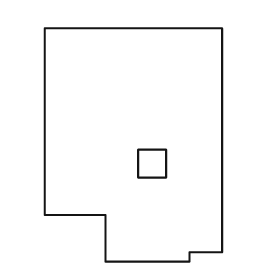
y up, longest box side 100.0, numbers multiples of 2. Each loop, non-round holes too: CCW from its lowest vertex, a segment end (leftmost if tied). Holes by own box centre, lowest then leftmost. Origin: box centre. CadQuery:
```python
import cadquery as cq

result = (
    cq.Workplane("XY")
    .moveTo(-12.0, -50.0)
    .lineTo(24.0, -50.0)
    .lineTo(24.0, -46.0)
    .lineTo(38.0, -46.0)
    .lineTo(38.0, 50.0)
    .lineTo(-38.0, 50.0)
    .lineTo(-38.0, -30.0)
    .lineTo(-12.0, -30.0)
    .close()
    .moveTo(2.0, -14.0)
    .lineTo(14.0, -14.0)
    .lineTo(14.0, -2.0)
    .lineTo(2.0, -2.0)
    .close()
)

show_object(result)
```